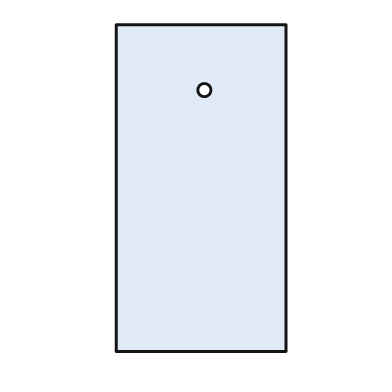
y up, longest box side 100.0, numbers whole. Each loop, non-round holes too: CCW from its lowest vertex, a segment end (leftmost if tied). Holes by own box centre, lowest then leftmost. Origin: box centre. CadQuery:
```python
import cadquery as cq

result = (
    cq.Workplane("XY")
    .moveTo(-26.0, -50.0)
    .lineTo(26.0, -50.0)
    .lineTo(26.0, 50.0)
    .lineTo(-26.0, 50.0)
    .close()
    .moveTo(1.0, 30.0)
    .circle(2.0)
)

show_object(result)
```